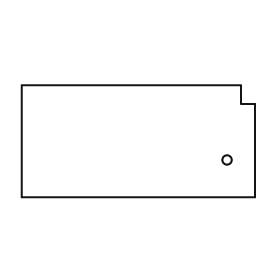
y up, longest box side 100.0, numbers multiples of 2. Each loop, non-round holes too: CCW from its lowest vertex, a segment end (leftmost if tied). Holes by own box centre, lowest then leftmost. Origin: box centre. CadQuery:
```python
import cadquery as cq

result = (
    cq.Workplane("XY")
    .moveTo(-50.0, -24.0)
    .lineTo(50.0, -24.0)
    .lineTo(50.0, 16.0)
    .lineTo(44.0, 16.0)
    .lineTo(44.0, 24.0)
    .lineTo(-50.0, 24.0)
    .close()
    .moveTo(38.0, -8.0)
    .circle(2.0)
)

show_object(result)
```